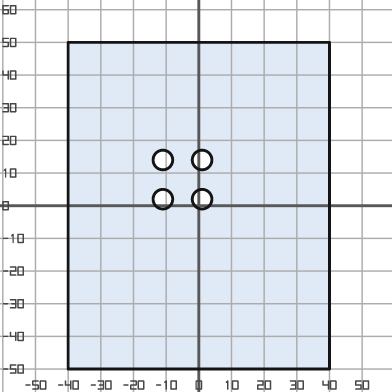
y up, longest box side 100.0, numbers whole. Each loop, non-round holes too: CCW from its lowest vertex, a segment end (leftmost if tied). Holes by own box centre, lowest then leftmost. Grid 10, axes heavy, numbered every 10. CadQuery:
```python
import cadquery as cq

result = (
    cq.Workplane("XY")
    .moveTo(-40.0, -50.0)
    .lineTo(40.0, -50.0)
    .lineTo(40.0, 50.0)
    .lineTo(-40.0, 50.0)
    .close()
    .moveTo(-11.0, 2.0)
    .circle(3.0)
    .moveTo(1.0, 2.0)
    .circle(3.0)
    .moveTo(-11.0, 14.0)
    .circle(3.0)
    .moveTo(1.0, 14.0)
    .circle(3.0)
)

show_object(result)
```